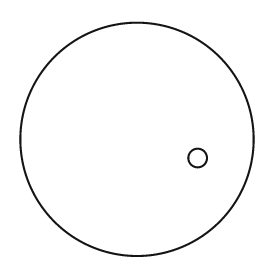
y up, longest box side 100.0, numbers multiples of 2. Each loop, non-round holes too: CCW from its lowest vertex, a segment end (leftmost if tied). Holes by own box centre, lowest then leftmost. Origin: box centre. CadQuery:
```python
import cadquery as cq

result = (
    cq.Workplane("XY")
    .moveTo(0.0, 0.0)
    .circle(50.0)
    .moveTo(26.0, -8.0)
    .circle(4.0)
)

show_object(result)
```